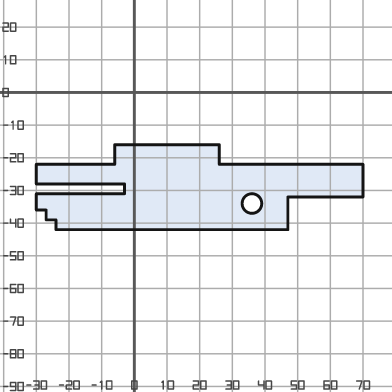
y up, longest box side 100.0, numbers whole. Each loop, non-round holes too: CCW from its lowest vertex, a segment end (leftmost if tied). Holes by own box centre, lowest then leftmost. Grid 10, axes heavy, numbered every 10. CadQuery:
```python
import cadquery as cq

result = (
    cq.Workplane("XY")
    .moveTo(-24.0, -42.0)
    .lineTo(47.0, -42.0)
    .lineTo(47.0, -32.0)
    .lineTo(70.0, -32.0)
    .lineTo(70.0, -22.0)
    .lineTo(26.0, -22.0)
    .lineTo(26.0, -16.0)
    .lineTo(-6.0, -16.0)
    .lineTo(-6.0, -22.0)
    .lineTo(-30.0, -22.0)
    .lineTo(-30.0, -28.0)
    .lineTo(-3.0, -28.0)
    .lineTo(-3.0, -31.0)
    .lineTo(-30.0, -31.0)
    .lineTo(-30.0, -36.0)
    .lineTo(-27.0, -36.0)
    .lineTo(-27.0, -39.0)
    .lineTo(-24.0, -39.0)
    .close()
    .moveTo(36.0, -34.0)
    .circle(3.0)
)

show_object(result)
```